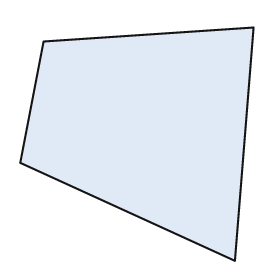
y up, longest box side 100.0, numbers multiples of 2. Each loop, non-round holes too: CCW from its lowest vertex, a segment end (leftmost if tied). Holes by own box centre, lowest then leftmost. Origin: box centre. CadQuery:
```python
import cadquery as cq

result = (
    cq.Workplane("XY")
    .moveTo(42.0, -50.0)
    .lineTo(50.0, 50.0)
    .lineTo(-40.0, 44.0)
    .lineTo(-50.0, -8.0)
    .close()
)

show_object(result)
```